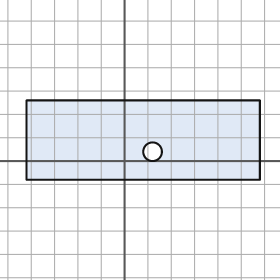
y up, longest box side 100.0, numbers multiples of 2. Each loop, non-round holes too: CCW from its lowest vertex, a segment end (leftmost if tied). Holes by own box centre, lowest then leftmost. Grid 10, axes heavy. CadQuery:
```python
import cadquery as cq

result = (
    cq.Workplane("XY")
    .moveTo(-42.0, -8.0)
    .lineTo(58.0, -8.0)
    .lineTo(58.0, 26.0)
    .lineTo(-42.0, 26.0)
    .close()
    .moveTo(12.0, 4.0)
    .circle(4.0)
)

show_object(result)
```